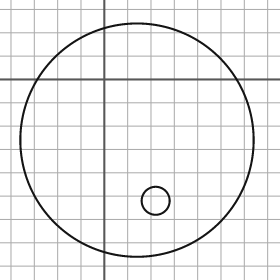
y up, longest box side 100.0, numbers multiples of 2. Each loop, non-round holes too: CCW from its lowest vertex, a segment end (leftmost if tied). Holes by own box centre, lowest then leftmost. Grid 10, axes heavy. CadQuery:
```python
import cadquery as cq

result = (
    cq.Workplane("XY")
    .moveTo(14.0, -26.0)
    .circle(50.0)
    .moveTo(22.0, -52.0)
    .circle(6.0)
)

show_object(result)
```